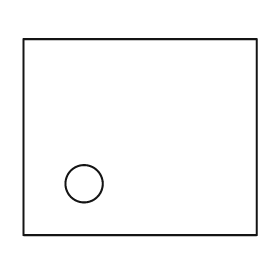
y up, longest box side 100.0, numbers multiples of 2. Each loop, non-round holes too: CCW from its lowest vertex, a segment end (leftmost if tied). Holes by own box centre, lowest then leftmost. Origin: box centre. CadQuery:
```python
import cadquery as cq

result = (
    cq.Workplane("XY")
    .moveTo(-50.0, -42.0)
    .lineTo(50.0, -42.0)
    .lineTo(50.0, 42.0)
    .lineTo(-50.0, 42.0)
    .close()
    .moveTo(-24.0, -20.0)
    .circle(8.0)
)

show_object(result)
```